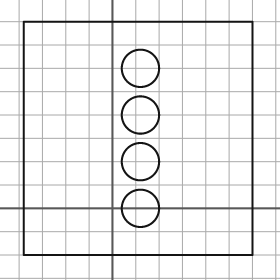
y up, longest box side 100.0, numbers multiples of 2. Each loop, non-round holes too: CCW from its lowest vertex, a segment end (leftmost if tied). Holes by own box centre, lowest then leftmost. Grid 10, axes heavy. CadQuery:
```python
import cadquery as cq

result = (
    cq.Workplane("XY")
    .moveTo(-38.0, -20.0)
    .lineTo(60.0, -20.0)
    .lineTo(60.0, 80.0)
    .lineTo(-38.0, 80.0)
    .close()
    .moveTo(12.0, 0.0)
    .circle(8.0)
    .moveTo(12.0, 20.0)
    .circle(8.0)
    .moveTo(12.0, 40.0)
    .circle(8.0)
    .moveTo(12.0, 60.0)
    .circle(8.0)
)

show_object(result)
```